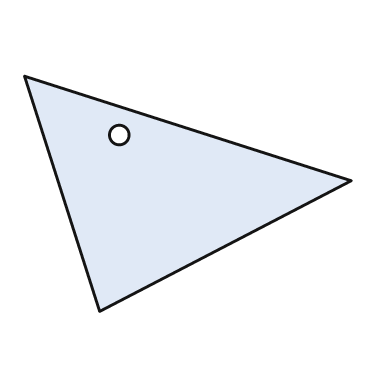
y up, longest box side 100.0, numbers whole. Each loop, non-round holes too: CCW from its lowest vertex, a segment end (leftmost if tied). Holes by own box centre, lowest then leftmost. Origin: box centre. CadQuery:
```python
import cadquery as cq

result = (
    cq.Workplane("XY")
    .moveTo(-27.0, -36.0)
    .lineTo(50.0, 4.0)
    .lineTo(-50.0, 36.0)
    .close()
    .moveTo(-21.0, 18.0)
    .circle(3.0)
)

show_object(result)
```